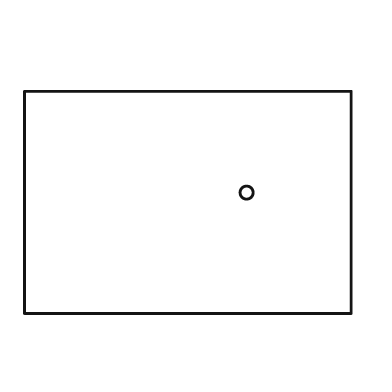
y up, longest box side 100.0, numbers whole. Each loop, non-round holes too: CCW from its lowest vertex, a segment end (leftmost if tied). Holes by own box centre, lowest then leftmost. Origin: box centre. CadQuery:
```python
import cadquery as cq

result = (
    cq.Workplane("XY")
    .moveTo(-50.0, -34.0)
    .lineTo(50.0, -34.0)
    .lineTo(50.0, 34.0)
    .lineTo(-50.0, 34.0)
    .close()
    .moveTo(18.0, 3.0)
    .circle(2.0)
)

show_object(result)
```